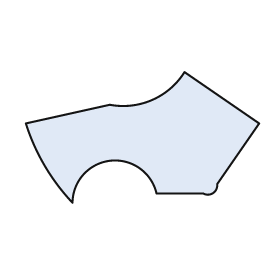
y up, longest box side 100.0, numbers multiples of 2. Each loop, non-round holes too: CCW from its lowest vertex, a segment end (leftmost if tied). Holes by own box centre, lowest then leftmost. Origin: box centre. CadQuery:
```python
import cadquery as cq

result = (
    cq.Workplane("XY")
    .moveTo(-30.0, -28.0)
    .threePointArc((-14.0, -10.0), (6.0, -24.0))
    .lineTo(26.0, -24.0)
    .threePointArc((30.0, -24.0), (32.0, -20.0))
    .lineTo(50.0, 6.0)
    .lineTo(18.0, 28.0)
    .threePointArc((4.0, 16.0), (-14.0, 14.0))
    .lineTo(-50.0, 6.0)
    .threePointArc((-42.0, -12.0), (-30.0, -28.0))
    .close()
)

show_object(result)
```